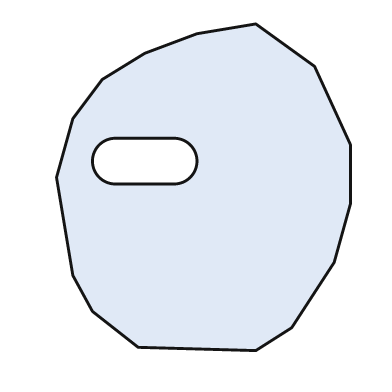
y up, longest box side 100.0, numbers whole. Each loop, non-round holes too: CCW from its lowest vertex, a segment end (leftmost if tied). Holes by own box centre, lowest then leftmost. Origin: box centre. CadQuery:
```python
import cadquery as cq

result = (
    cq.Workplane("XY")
    .moveTo(16.0, -50.0)
    .lineTo(27.0, -43.0)
    .lineTo(40.0, -23.0)
    .lineTo(45.0, -5.0)
    .lineTo(45.0, 13.0)
    .lineTo(34.0, 37.0)
    .lineTo(16.0, 50.0)
    .lineTo(-2.0, 47.0)
    .lineTo(-18.0, 41.0)
    .lineTo(-31.0, 33.0)
    .lineTo(-40.0, 21.0)
    .lineTo(-45.0, 3.0)
    .lineTo(-40.0, -27.0)
    .lineTo(-34.0, -38.0)
    .lineTo(-20.0, -49.0)
    .close()
    .moveTo(-27.0, 1.0)
    .lineTo(-9.0, 1.0)
    .threePointArc((-2.0, 8.0), (-9.0, 15.0))
    .lineTo(-27.0, 15.0)
    .threePointArc((-34.0, 8.0), (-27.0, 1.0))
    .close()
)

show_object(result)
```